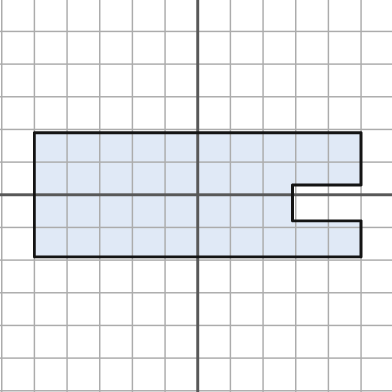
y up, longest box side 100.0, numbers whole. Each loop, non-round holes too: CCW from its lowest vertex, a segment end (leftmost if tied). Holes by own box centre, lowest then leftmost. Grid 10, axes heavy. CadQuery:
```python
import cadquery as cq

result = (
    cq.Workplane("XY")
    .moveTo(-50.0, -19.0)
    .lineTo(50.0, -19.0)
    .lineTo(50.0, -8.0)
    .lineTo(29.0, -8.0)
    .lineTo(29.0, 3.0)
    .lineTo(50.0, 3.0)
    .lineTo(50.0, 19.0)
    .lineTo(-50.0, 19.0)
    .close()
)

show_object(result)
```